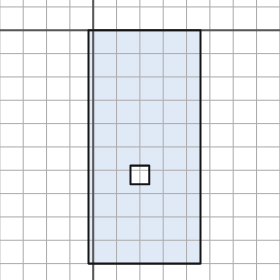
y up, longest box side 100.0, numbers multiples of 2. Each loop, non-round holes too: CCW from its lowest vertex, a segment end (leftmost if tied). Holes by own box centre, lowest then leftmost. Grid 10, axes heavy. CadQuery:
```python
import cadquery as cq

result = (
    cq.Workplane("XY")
    .moveTo(-2.0, -100.0)
    .lineTo(46.0, -100.0)
    .lineTo(46.0, 0.0)
    .lineTo(-2.0, 0.0)
    .close()
    .moveTo(16.0, -66.0)
    .lineTo(24.0, -66.0)
    .lineTo(24.0, -58.0)
    .lineTo(16.0, -58.0)
    .close()
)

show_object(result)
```